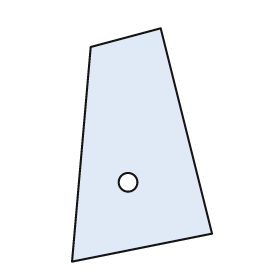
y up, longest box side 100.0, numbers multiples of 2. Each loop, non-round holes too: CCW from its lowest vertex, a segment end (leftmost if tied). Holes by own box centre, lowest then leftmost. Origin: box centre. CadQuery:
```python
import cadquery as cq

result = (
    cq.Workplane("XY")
    .moveTo(-30.0, -50.0)
    .lineTo(30.0, -38.0)
    .lineTo(8.0, 50.0)
    .lineTo(-22.0, 42.0)
    .close()
    .moveTo(-6.0, -16.0)
    .circle(4.0)
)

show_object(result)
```